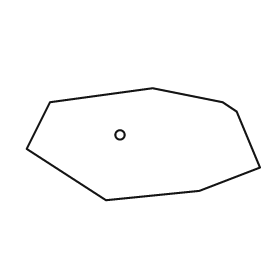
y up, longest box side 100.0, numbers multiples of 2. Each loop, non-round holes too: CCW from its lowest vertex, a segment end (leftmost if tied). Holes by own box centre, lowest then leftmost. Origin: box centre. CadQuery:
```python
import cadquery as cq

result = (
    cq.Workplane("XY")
    .moveTo(-16.0, -24.0)
    .lineTo(24.0, -20.0)
    .lineTo(50.0, -10.0)
    .lineTo(40.0, 14.0)
    .lineTo(34.0, 18.0)
    .lineTo(4.0, 24.0)
    .lineTo(-40.0, 18.0)
    .lineTo(-50.0, -2.0)
    .close()
    .moveTo(-10.0, 4.0)
    .circle(2.0)
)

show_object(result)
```